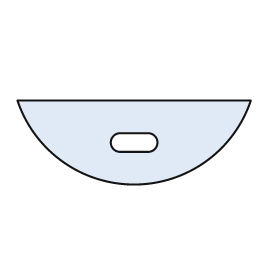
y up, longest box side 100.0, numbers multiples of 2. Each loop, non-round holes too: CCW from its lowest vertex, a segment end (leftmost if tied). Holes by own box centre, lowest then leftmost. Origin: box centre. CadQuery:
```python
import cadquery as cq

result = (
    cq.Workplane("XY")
    .moveTo(-50.0, 18.0)
    .threePointArc((0.0, -18.0), (50.0, 18.0))
    .close()
    .moveTo(-6.0, -4.0)
    .lineTo(6.0, -4.0)
    .threePointArc((10.0, 0.0), (6.0, 4.0))
    .lineTo(-6.0, 4.0)
    .threePointArc((-10.0, 0.0), (-6.0, -4.0))
    .close()
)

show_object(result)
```